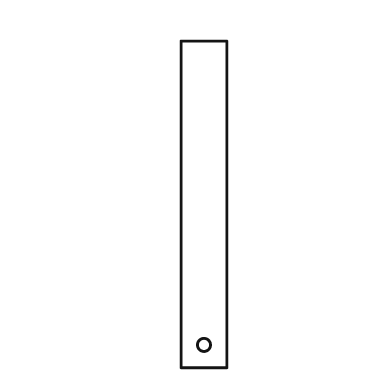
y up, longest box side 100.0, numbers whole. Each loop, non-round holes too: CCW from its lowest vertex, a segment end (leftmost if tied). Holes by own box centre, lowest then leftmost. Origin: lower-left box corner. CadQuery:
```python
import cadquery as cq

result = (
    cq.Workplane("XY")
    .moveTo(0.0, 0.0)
    .lineTo(14.0, 0.0)
    .lineTo(14.0, 100.0)
    .lineTo(0.0, 100.0)
    .close()
    .moveTo(7.0, 7.0)
    .circle(2.0)
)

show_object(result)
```